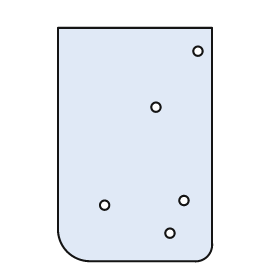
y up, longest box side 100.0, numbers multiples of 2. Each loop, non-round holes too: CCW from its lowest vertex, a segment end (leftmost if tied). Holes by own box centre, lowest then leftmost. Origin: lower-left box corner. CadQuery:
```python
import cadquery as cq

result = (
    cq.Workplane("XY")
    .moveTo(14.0, 0.0)
    .lineTo(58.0, 0.0)
    .threePointArc((64.0, 2.0), (66.0, 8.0))
    .lineTo(66.0, 100.0)
    .lineTo(0.0, 100.0)
    .lineTo(0.0, 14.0)
    .threePointArc((4.0, 4.0), (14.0, 0.0))
    .close()
    .moveTo(48.0, 12.0)
    .circle(2.0)
    .moveTo(20.0, 24.0)
    .circle(2.0)
    .moveTo(54.0, 26.0)
    .circle(2.0)
    .moveTo(42.0, 66.0)
    .circle(2.0)
    .moveTo(60.0, 90.0)
    .circle(2.0)
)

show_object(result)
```